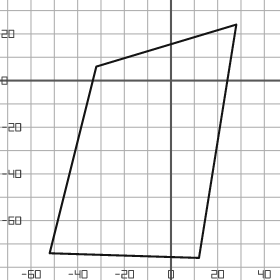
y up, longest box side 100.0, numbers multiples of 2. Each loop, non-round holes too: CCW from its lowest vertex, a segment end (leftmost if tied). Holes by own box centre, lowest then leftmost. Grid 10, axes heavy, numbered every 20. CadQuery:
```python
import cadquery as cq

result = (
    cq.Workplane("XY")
    .moveTo(12.0, -76.0)
    .lineTo(28.0, 24.0)
    .lineTo(-32.0, 6.0)
    .lineTo(-52.0, -74.0)
    .close()
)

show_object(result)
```